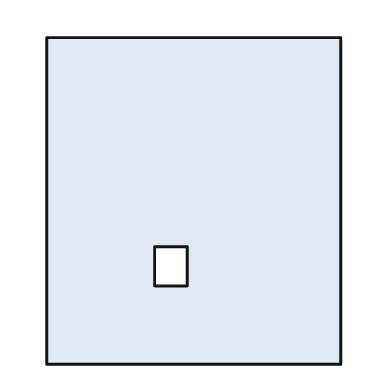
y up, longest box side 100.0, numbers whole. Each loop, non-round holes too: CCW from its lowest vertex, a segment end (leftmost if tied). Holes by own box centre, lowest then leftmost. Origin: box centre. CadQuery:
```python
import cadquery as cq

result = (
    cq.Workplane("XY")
    .moveTo(-45.0, -50.0)
    .lineTo(45.0, -50.0)
    .lineTo(45.0, 50.0)
    .lineTo(-45.0, 50.0)
    .close()
    .moveTo(-12.0, -26.0)
    .lineTo(-2.0, -26.0)
    .lineTo(-2.0, -14.0)
    .lineTo(-12.0, -14.0)
    .close()
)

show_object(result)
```